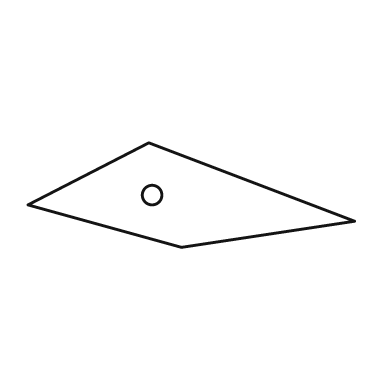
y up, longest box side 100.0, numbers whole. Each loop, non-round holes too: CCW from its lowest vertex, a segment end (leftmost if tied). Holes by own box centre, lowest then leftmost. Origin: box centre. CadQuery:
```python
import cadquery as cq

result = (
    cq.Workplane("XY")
    .moveTo(-3.0, -16.0)
    .lineTo(50.0, -8.0)
    .lineTo(-13.0, 16.0)
    .lineTo(-50.0, -3.0)
    .close()
    .moveTo(-12.0, 0.0)
    .circle(3.0)
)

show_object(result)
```